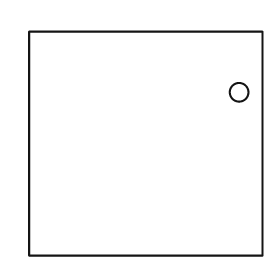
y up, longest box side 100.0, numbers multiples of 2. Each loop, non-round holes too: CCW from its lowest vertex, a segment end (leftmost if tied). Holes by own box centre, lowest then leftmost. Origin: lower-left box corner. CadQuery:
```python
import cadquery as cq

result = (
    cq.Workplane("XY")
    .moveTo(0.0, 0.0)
    .lineTo(100.0, 0.0)
    .lineTo(100.0, 96.0)
    .lineTo(0.0, 96.0)
    .close()
    .moveTo(90.0, 70.0)
    .circle(4.0)
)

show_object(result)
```